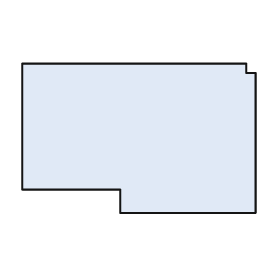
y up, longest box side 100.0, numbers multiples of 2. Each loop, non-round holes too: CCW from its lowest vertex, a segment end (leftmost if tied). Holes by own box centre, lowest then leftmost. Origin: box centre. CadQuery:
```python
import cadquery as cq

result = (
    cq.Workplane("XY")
    .moveTo(-8.0, -32.0)
    .lineTo(50.0, -32.0)
    .lineTo(50.0, 28.0)
    .lineTo(46.0, 28.0)
    .lineTo(46.0, 32.0)
    .lineTo(-50.0, 32.0)
    .lineTo(-50.0, -22.0)
    .lineTo(-8.0, -22.0)
    .close()
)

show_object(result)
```